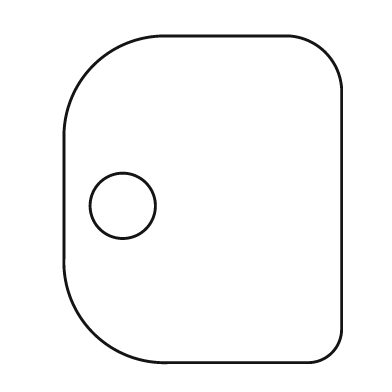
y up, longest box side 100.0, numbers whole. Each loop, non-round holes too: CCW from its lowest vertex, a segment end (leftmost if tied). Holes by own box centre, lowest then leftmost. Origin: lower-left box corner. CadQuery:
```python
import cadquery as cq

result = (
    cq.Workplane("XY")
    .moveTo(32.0, 0.0)
    .lineTo(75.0, 0.0)
    .threePointArc((82.0, 3.0), (85.0, 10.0))
    .lineTo(85.0, 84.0)
    .threePointArc((80.0, 95.0), (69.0, 100.0))
    .lineTo(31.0, 100.0)
    .threePointArc((9.0, 91.0), (0.0, 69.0))
    .lineTo(0.0, 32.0)
    .threePointArc((9.0, 9.0), (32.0, 0.0))
    .close()
    .moveTo(18.0, 48.0)
    .circle(10.0)
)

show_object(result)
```